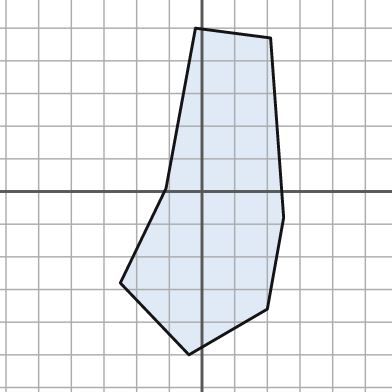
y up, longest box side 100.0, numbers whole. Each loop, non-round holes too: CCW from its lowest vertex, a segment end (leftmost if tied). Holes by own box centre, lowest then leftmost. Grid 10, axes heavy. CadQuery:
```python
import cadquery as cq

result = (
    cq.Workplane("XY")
    .moveTo(-4.0, -50.0)
    .lineTo(20.0, -36.0)
    .lineTo(25.0, -8.0)
    .lineTo(21.0, 47.0)
    .lineTo(-2.0, 50.0)
    .lineTo(-11.0, 1.0)
    .lineTo(-25.0, -28.0)
    .close()
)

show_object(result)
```